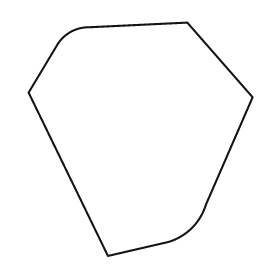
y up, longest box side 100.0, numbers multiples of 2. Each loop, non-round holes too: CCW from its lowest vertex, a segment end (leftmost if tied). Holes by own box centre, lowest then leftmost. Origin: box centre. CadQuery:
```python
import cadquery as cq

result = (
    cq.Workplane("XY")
    .moveTo(-14.0, -50.0)
    .lineTo(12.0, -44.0)
    .threePointArc((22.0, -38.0), (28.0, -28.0))
    .lineTo(48.0, 18.0)
    .lineTo(20.0, 50.0)
    .lineTo(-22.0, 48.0)
    .threePointArc((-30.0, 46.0), (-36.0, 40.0))
    .lineTo(-48.0, 20.0)
    .close()
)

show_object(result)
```